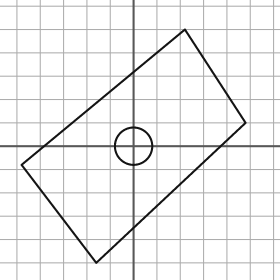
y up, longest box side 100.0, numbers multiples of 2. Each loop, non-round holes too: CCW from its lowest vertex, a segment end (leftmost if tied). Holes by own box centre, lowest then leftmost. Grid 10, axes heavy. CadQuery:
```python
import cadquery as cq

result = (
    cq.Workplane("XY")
    .moveTo(-16.0, -50.0)
    .lineTo(48.0, 10.0)
    .lineTo(22.0, 50.0)
    .lineTo(-48.0, -8.0)
    .close()
    .moveTo(0.0, 0.0)
    .circle(8.0)
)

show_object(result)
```